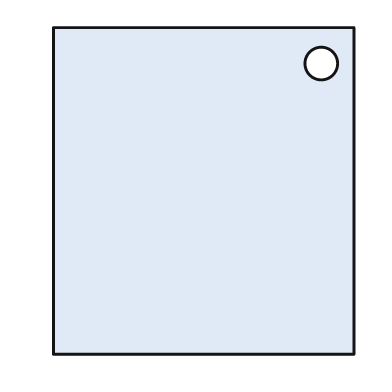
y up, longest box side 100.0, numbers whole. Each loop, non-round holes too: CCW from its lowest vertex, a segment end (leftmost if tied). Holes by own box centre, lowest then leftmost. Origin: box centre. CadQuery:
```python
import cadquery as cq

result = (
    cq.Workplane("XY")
    .moveTo(-46.0, -50.0)
    .lineTo(46.0, -50.0)
    .lineTo(46.0, 50.0)
    .lineTo(-46.0, 50.0)
    .close()
    .moveTo(36.0, 39.0)
    .circle(5.0)
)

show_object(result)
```